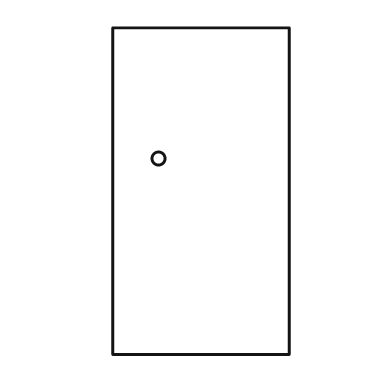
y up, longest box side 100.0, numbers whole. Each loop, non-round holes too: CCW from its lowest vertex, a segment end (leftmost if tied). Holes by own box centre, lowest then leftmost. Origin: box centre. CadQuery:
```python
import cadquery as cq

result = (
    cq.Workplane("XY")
    .moveTo(-27.0, -50.0)
    .lineTo(27.0, -50.0)
    .lineTo(27.0, 50.0)
    .lineTo(-27.0, 50.0)
    .close()
    .moveTo(-13.0, 10.0)
    .circle(2.0)
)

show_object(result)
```